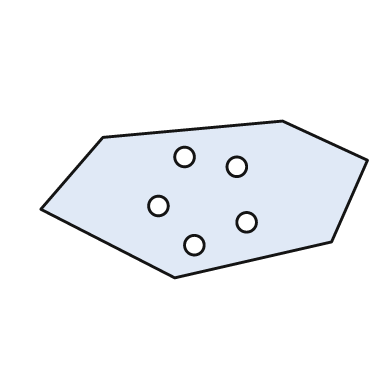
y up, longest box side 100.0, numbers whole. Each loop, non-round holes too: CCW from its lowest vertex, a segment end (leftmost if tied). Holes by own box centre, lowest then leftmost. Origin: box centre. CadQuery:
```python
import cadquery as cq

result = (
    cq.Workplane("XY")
    .moveTo(-9.0, -24.0)
    .lineTo(39.0, -13.0)
    .lineTo(50.0, 12.0)
    .lineTo(24.0, 24.0)
    .lineTo(-31.0, 19.0)
    .lineTo(-50.0, -3.0)
    .close()
    .moveTo(-3.0, -14.0)
    .circle(3.0)
    .moveTo(13.0, -7.0)
    .circle(3.0)
    .moveTo(-14.0, -2.0)
    .circle(3.0)
    .moveTo(10.0, 10.0)
    .circle(3.0)
    .moveTo(-6.0, 13.0)
    .circle(3.0)
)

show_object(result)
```